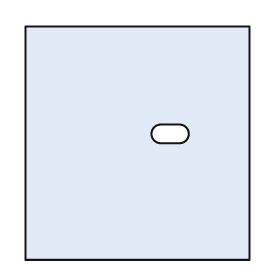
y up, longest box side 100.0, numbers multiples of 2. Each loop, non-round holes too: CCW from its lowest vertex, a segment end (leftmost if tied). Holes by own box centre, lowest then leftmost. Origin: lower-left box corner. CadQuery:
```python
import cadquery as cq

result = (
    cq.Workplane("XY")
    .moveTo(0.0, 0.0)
    .lineTo(96.0, 0.0)
    .lineTo(96.0, 100.0)
    .lineTo(0.0, 100.0)
    .close()
    .moveTo(58.0, 50.0)
    .lineTo(66.0, 50.0)
    .threePointArc((70.0, 54.0), (66.0, 58.0))
    .lineTo(58.0, 58.0)
    .threePointArc((54.0, 54.0), (58.0, 50.0))
    .close()
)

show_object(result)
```